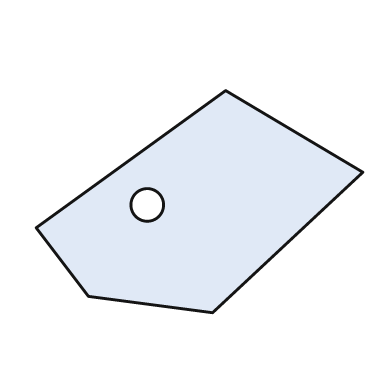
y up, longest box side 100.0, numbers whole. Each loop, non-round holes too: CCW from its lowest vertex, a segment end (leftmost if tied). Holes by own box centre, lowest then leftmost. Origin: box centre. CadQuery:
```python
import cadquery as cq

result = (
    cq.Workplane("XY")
    .moveTo(4.0, -34.0)
    .lineTo(50.0, 9.0)
    .lineTo(8.0, 34.0)
    .lineTo(-50.0, -8.0)
    .lineTo(-34.0, -29.0)
    .close()
    .moveTo(-16.0, -1.0)
    .circle(5.0)
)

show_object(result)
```